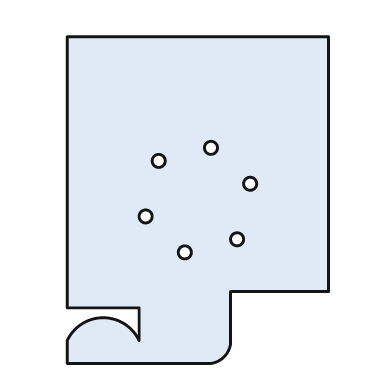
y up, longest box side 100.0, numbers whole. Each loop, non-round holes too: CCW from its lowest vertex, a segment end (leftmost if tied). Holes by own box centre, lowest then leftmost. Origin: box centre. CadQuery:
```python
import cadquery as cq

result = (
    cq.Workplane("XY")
    .moveTo(-40.0, -50.0)
    .lineTo(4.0, -50.0)
    .threePointArc((8.0, -48.0), (10.0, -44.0))
    .lineTo(10.0, -28.0)
    .lineTo(40.0, -28.0)
    .lineTo(40.0, 50.0)
    .lineTo(-40.0, 50.0)
    .lineTo(-40.0, -33.0)
    .lineTo(-18.0, -33.0)
    .lineTo(-18.0, -43.0)
    .threePointArc((-29.0, -36.0), (-40.0, -43.0))
    .close()
    .moveTo(-4.0, -16.0)
    .circle(2.0)
    .moveTo(12.0, -12.0)
    .circle(2.0)
    .moveTo(-16.0, -5.0)
    .circle(2.0)
    .moveTo(16.0, 5.0)
    .circle(2.0)
    .moveTo(-12.0, 12.0)
    .circle(2.0)
    .moveTo(4.0, 16.0)
    .circle(2.0)
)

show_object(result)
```